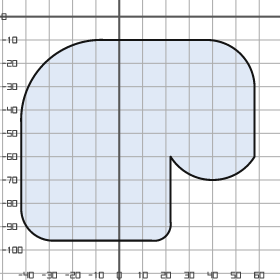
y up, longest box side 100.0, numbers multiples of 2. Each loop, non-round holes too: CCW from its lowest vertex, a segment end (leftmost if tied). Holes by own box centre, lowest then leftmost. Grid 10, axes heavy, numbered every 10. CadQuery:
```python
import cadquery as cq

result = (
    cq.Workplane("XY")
    .moveTo(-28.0, -96.0)
    .lineTo(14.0, -96.0)
    .threePointArc((20.0, -94.0), (22.0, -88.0))
    .lineTo(22.0, -60.0)
    .threePointArc((40.0, -70.0), (58.0, -60.0))
    .lineTo(58.0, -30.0)
    .threePointArc((52.0, -16.0), (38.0, -10.0))
    .lineTo(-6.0, -10.0)
    .threePointArc((-32.0, -20.0), (-42.0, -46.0))
    .lineTo(-42.0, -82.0)
    .threePointArc((-38.0, -92.0), (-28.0, -96.0))
    .close()
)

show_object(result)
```